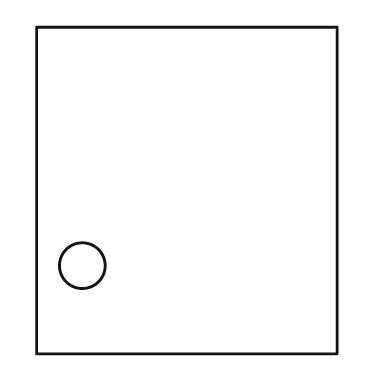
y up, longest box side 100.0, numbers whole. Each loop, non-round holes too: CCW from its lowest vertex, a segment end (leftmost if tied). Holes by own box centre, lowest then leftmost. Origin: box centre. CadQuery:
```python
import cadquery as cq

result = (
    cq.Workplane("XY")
    .moveTo(-46.0, -50.0)
    .lineTo(46.0, -50.0)
    .lineTo(46.0, 50.0)
    .lineTo(-46.0, 50.0)
    .close()
    .moveTo(-32.0, -23.0)
    .circle(7.0)
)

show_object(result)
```